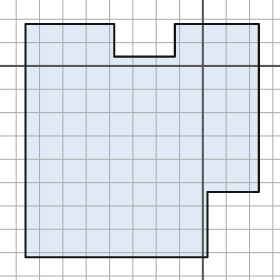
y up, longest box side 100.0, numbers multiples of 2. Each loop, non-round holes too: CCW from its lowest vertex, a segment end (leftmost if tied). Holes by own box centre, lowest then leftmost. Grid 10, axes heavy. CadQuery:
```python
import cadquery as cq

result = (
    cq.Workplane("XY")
    .moveTo(-76.0, -82.0)
    .lineTo(2.0, -82.0)
    .lineTo(2.0, -54.0)
    .lineTo(24.0, -54.0)
    .lineTo(24.0, 18.0)
    .lineTo(-12.0, 18.0)
    .lineTo(-12.0, 4.0)
    .lineTo(-38.0, 4.0)
    .lineTo(-38.0, 18.0)
    .lineTo(-76.0, 18.0)
    .close()
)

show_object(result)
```